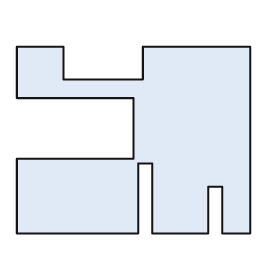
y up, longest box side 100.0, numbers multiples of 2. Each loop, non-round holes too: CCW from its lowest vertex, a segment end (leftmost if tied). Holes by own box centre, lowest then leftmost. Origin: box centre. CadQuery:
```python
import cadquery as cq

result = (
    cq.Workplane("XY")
    .moveTo(-50.0, -40.0)
    .lineTo(2.0, -40.0)
    .lineTo(2.0, -10.0)
    .lineTo(8.0, -10.0)
    .lineTo(8.0, -40.0)
    .lineTo(32.0, -40.0)
    .lineTo(32.0, -20.0)
    .lineTo(38.0, -20.0)
    .lineTo(38.0, -40.0)
    .lineTo(50.0, -40.0)
    .lineTo(50.0, 40.0)
    .lineTo(4.0, 40.0)
    .lineTo(4.0, 26.0)
    .lineTo(-30.0, 26.0)
    .lineTo(-30.0, 40.0)
    .lineTo(-50.0, 40.0)
    .lineTo(-50.0, 18.0)
    .lineTo(0.0, 18.0)
    .lineTo(0.0, -8.0)
    .lineTo(-50.0, -8.0)
    .close()
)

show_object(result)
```